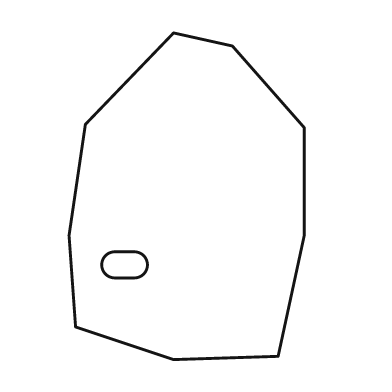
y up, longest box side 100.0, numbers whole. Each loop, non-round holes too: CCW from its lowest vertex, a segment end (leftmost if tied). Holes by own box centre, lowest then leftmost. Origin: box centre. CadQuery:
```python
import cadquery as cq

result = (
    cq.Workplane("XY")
    .moveTo(-4.0, -50.0)
    .lineTo(28.0, -49.0)
    .lineTo(36.0, -12.0)
    .lineTo(36.0, 21.0)
    .lineTo(14.0, 46.0)
    .lineTo(-4.0, 50.0)
    .lineTo(-31.0, 22.0)
    .lineTo(-36.0, -12.0)
    .lineTo(-34.0, -40.0)
    .close()
    .moveTo(-22.0, -25.0)
    .lineTo(-16.0, -25.0)
    .threePointArc((-12.0, -21.0), (-16.0, -17.0))
    .lineTo(-22.0, -17.0)
    .threePointArc((-26.0, -21.0), (-22.0, -25.0))
    .close()
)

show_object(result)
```